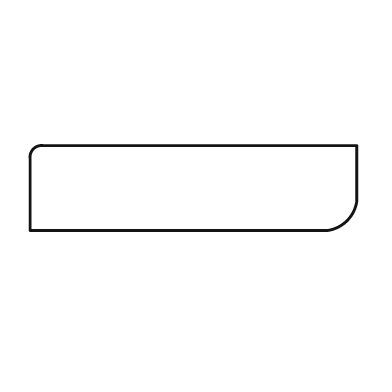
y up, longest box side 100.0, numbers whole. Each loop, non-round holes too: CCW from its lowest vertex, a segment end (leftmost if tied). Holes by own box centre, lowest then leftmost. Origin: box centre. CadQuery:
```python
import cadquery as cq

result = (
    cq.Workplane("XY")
    .moveTo(-50.0, -13.0)
    .lineTo(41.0, -13.0)
    .threePointArc((47.0, -10.0), (50.0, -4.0))
    .lineTo(50.0, 13.0)
    .lineTo(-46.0, 13.0)
    .threePointArc((-49.0, 12.0), (-50.0, 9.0))
    .close()
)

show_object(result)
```